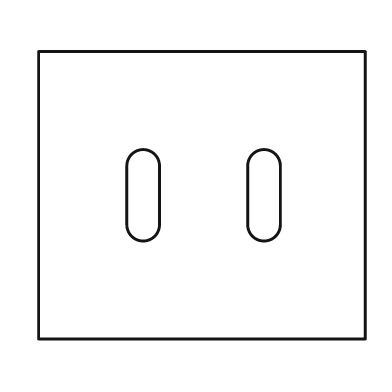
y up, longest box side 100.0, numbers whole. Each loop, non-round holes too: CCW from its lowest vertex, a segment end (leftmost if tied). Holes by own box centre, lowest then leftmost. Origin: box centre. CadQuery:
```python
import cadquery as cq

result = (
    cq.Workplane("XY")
    .moveTo(-50.0, -44.0)
    .lineTo(50.0, -44.0)
    .lineTo(50.0, 44.0)
    .lineTo(-50.0, 44.0)
    .close()
    .moveTo(-23.0, -9.0)
    .threePointArc((-18.0, -14.0), (-13.0, -9.0))
    .lineTo(-13.0, 9.0)
    .threePointArc((-18.0, 14.0), (-23.0, 9.0))
    .close()
    .moveTo(14.0, -9.0)
    .threePointArc((19.0, -14.0), (24.0, -9.0))
    .lineTo(24.0, 9.0)
    .threePointArc((19.0, 14.0), (14.0, 9.0))
    .close()
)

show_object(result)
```